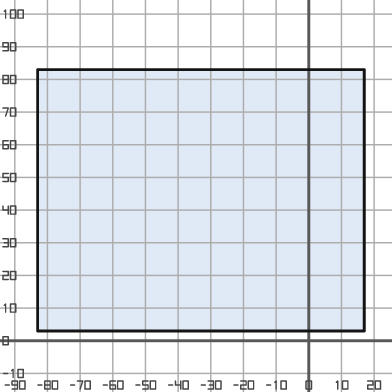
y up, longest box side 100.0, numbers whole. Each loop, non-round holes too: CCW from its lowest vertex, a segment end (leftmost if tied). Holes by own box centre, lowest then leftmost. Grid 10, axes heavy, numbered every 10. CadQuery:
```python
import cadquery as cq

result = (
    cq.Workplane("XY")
    .moveTo(-83.0, 3.0)
    .lineTo(17.0, 3.0)
    .lineTo(17.0, 83.0)
    .lineTo(-83.0, 83.0)
    .close()
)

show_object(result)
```